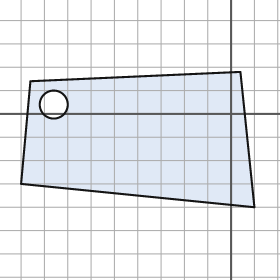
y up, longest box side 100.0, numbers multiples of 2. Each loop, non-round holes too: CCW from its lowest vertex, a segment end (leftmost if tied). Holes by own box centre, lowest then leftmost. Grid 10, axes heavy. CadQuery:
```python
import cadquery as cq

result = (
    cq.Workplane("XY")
    .moveTo(10.0, -40.0)
    .lineTo(4.0, 18.0)
    .lineTo(-86.0, 14.0)
    .lineTo(-90.0, -30.0)
    .close()
    .moveTo(-76.0, 4.0)
    .circle(6.0)
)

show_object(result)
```